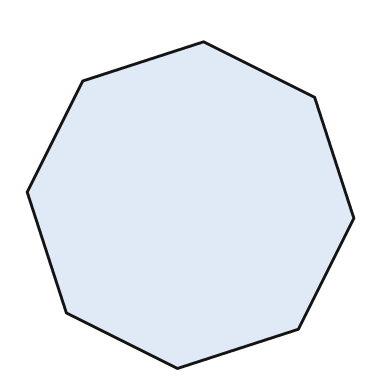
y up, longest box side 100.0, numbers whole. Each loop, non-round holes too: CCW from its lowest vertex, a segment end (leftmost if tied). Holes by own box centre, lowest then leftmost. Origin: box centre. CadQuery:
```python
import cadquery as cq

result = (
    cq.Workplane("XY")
    .moveTo(-4.0, -50.0)
    .lineTo(33.0, -38.0)
    .lineTo(50.0, -4.0)
    .lineTo(38.0, 33.0)
    .lineTo(4.0, 50.0)
    .lineTo(-33.0, 38.0)
    .lineTo(-50.0, 4.0)
    .lineTo(-38.0, -33.0)
    .close()
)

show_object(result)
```